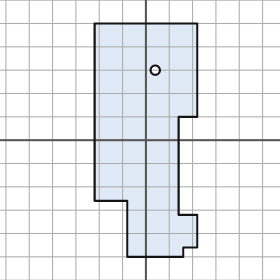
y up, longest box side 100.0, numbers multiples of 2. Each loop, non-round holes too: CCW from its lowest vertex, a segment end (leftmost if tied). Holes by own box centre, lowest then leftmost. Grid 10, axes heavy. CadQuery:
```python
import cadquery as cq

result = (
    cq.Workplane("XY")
    .moveTo(-8.0, -50.0)
    .lineTo(16.0, -50.0)
    .lineTo(16.0, -46.0)
    .lineTo(22.0, -46.0)
    .lineTo(22.0, -32.0)
    .lineTo(14.0, -32.0)
    .lineTo(14.0, 10.0)
    .lineTo(22.0, 10.0)
    .lineTo(22.0, 50.0)
    .lineTo(-22.0, 50.0)
    .lineTo(-22.0, -26.0)
    .lineTo(-8.0, -26.0)
    .close()
    .moveTo(4.0, 30.0)
    .circle(2.0)
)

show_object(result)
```